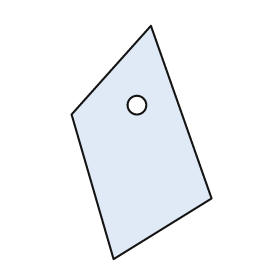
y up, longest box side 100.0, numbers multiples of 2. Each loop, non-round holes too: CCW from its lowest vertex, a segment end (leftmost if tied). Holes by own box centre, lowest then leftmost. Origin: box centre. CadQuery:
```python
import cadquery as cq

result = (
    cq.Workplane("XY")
    .moveTo(-12.0, -50.0)
    .lineTo(30.0, -24.0)
    .lineTo(4.0, 50.0)
    .lineTo(-30.0, 12.0)
    .close()
    .moveTo(-2.0, 16.0)
    .circle(4.0)
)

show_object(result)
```